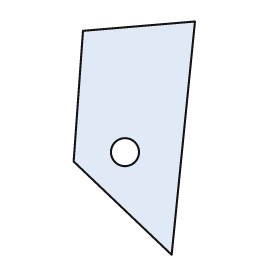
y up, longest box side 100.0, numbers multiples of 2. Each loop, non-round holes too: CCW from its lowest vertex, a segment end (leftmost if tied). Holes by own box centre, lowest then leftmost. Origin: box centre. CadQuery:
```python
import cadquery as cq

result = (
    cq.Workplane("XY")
    .moveTo(16.0, -50.0)
    .lineTo(26.0, 50.0)
    .lineTo(-22.0, 46.0)
    .lineTo(-26.0, -10.0)
    .close()
    .moveTo(-4.0, -6.0)
    .circle(6.0)
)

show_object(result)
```